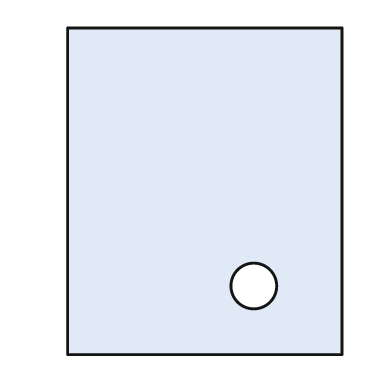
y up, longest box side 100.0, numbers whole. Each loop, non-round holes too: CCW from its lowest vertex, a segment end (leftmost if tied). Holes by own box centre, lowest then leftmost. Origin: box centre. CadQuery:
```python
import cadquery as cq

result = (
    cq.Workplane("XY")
    .moveTo(-42.0, -50.0)
    .lineTo(42.0, -50.0)
    .lineTo(42.0, 50.0)
    .lineTo(-42.0, 50.0)
    .close()
    .moveTo(15.0, -29.0)
    .circle(7.0)
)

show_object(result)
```